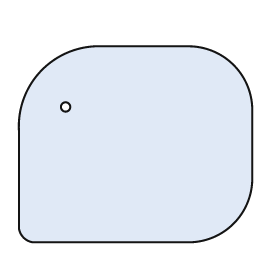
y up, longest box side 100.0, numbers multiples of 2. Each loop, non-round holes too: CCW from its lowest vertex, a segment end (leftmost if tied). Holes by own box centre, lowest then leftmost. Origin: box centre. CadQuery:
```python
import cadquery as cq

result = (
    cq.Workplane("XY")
    .moveTo(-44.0, -42.0)
    .lineTo(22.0, -42.0)
    .threePointArc((42.0, -34.0), (50.0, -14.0))
    .lineTo(50.0, 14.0)
    .threePointArc((42.0, 34.0), (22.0, 42.0))
    .lineTo(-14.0, 42.0)
    .threePointArc((-40.0, 32.0), (-50.0, 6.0))
    .lineTo(-50.0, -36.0)
    .threePointArc((-48.0, -40.0), (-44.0, -42.0))
    .close()
    .moveTo(-30.0, 16.0)
    .circle(2.0)
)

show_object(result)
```